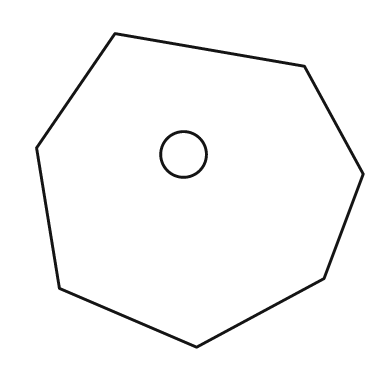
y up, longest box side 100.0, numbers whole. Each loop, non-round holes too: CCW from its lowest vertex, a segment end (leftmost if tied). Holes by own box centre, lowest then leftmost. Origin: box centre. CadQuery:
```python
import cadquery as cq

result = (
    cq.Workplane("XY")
    .moveTo(-1.0, -48.0)
    .lineTo(38.0, -27.0)
    .lineTo(50.0, 5.0)
    .lineTo(32.0, 38.0)
    .lineTo(-26.0, 48.0)
    .lineTo(-50.0, 13.0)
    .lineTo(-43.0, -30.0)
    .close()
    .moveTo(-5.0, 11.0)
    .circle(7.0)
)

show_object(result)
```